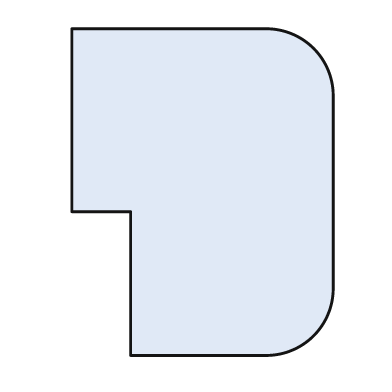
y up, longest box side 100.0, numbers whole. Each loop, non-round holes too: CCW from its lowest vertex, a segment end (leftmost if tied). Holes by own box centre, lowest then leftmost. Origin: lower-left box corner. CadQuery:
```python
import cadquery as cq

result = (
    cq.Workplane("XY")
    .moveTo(18.0, 0.0)
    .lineTo(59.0, 0.0)
    .threePointArc((74.0, 6.0), (80.0, 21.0))
    .lineTo(80.0, 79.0)
    .threePointArc((74.0, 94.0), (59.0, 100.0))
    .lineTo(0.0, 100.0)
    .lineTo(0.0, 44.0)
    .lineTo(18.0, 44.0)
    .close()
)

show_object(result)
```